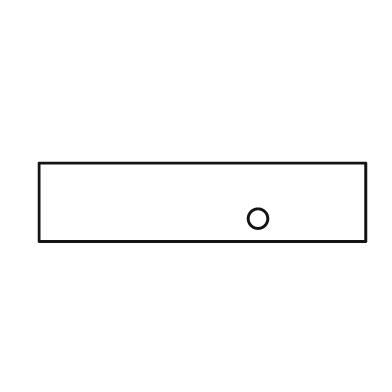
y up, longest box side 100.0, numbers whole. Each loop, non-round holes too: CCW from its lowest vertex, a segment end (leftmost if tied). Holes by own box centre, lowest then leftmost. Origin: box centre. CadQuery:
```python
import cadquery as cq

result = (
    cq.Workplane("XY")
    .moveTo(-50.0, -12.0)
    .lineTo(50.0, -12.0)
    .lineTo(50.0, 12.0)
    .lineTo(-50.0, 12.0)
    .close()
    .moveTo(17.0, -5.0)
    .circle(3.0)
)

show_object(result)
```